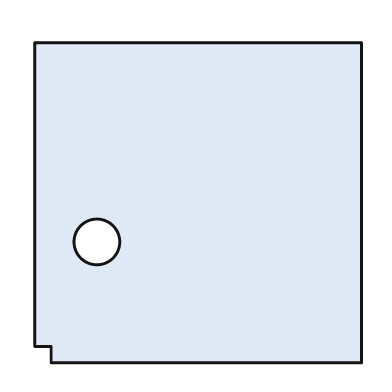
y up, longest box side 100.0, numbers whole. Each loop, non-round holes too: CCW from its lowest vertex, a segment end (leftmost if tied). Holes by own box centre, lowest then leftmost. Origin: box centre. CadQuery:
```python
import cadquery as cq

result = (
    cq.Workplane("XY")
    .moveTo(-45.0, -49.0)
    .lineTo(50.0, -49.0)
    .lineTo(50.0, 49.0)
    .lineTo(-50.0, 49.0)
    .lineTo(-50.0, -44.0)
    .lineTo(-45.0, -44.0)
    .close()
    .moveTo(-31.0, -12.0)
    .circle(7.0)
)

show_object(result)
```